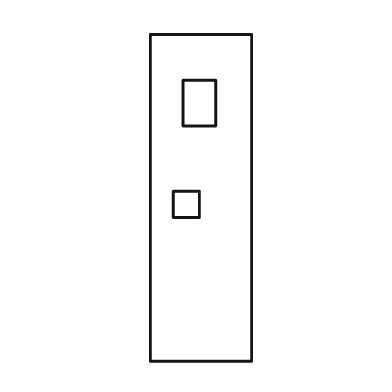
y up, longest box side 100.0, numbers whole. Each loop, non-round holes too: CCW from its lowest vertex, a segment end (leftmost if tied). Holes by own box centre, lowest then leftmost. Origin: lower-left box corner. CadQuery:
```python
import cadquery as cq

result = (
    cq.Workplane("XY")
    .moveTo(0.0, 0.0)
    .lineTo(31.0, 0.0)
    .lineTo(31.0, 100.0)
    .lineTo(0.0, 100.0)
    .close()
    .moveTo(7.0, 44.0)
    .lineTo(15.0, 44.0)
    .lineTo(15.0, 52.0)
    .lineTo(7.0, 52.0)
    .close()
    .moveTo(10.0, 72.0)
    .lineTo(20.0, 72.0)
    .lineTo(20.0, 86.0)
    .lineTo(10.0, 86.0)
    .close()
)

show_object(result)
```